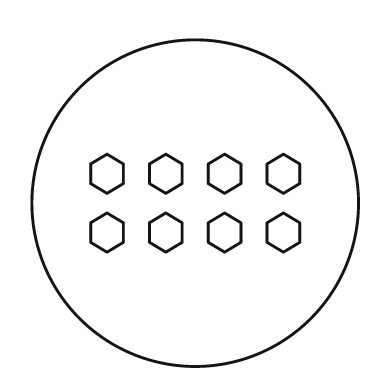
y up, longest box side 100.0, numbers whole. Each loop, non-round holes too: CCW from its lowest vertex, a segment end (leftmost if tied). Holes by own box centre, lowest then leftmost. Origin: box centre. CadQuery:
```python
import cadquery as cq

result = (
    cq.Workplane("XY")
    .moveTo(0.0, 0.0)
    .circle(50.0)
    .moveTo(-27.0, -15.0)
    .lineTo(-22.0, -12.0)
    .lineTo(-22.0, -6.0)
    .lineTo(-27.0, -3.0)
    .lineTo(-32.0, -6.0)
    .lineTo(-32.0, -12.0)
    .close()
    .moveTo(-9.0, -15.0)
    .lineTo(-4.0, -12.0)
    .lineTo(-4.0, -6.0)
    .lineTo(-9.0, -3.0)
    .lineTo(-14.0, -6.0)
    .lineTo(-14.0, -12.0)
    .close()
    .moveTo(9.0, -15.0)
    .lineTo(14.0, -12.0)
    .lineTo(14.0, -6.0)
    .lineTo(9.0, -3.0)
    .lineTo(4.0, -6.0)
    .lineTo(4.0, -12.0)
    .close()
    .moveTo(27.0, -15.0)
    .lineTo(32.0, -12.0)
    .lineTo(32.0, -6.0)
    .lineTo(27.0, -3.0)
    .lineTo(22.0, -6.0)
    .lineTo(22.0, -12.0)
    .close()
    .moveTo(-27.0, 3.0)
    .lineTo(-22.0, 6.0)
    .lineTo(-22.0, 12.0)
    .lineTo(-27.0, 15.0)
    .lineTo(-32.0, 12.0)
    .lineTo(-32.0, 6.0)
    .close()
    .moveTo(-9.0, 3.0)
    .lineTo(-4.0, 6.0)
    .lineTo(-4.0, 12.0)
    .lineTo(-9.0, 15.0)
    .lineTo(-14.0, 12.0)
    .lineTo(-14.0, 6.0)
    .close()
    .moveTo(9.0, 3.0)
    .lineTo(14.0, 6.0)
    .lineTo(14.0, 12.0)
    .lineTo(9.0, 15.0)
    .lineTo(4.0, 12.0)
    .lineTo(4.0, 6.0)
    .close()
    .moveTo(27.0, 3.0)
    .lineTo(32.0, 6.0)
    .lineTo(32.0, 12.0)
    .lineTo(27.0, 15.0)
    .lineTo(22.0, 12.0)
    .lineTo(22.0, 6.0)
    .close()
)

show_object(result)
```